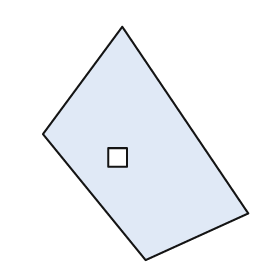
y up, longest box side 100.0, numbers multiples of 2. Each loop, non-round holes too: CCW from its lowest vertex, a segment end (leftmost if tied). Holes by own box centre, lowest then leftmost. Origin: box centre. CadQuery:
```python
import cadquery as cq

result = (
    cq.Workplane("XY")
    .moveTo(0.0, -50.0)
    .lineTo(44.0, -30.0)
    .lineTo(-10.0, 50.0)
    .lineTo(-44.0, 4.0)
    .close()
    .moveTo(-16.0, -10.0)
    .lineTo(-8.0, -10.0)
    .lineTo(-8.0, -2.0)
    .lineTo(-16.0, -2.0)
    .close()
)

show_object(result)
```